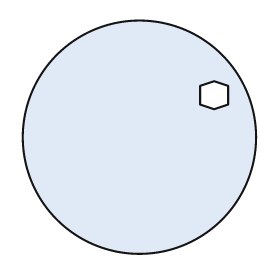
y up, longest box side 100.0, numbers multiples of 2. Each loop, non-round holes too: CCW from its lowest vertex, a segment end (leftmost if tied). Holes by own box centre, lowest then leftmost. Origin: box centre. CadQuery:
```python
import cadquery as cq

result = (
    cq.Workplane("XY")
    .moveTo(0.0, 0.0)
    .circle(50.0)
    .moveTo(32.0, 12.0)
    .lineTo(38.0, 14.0)
    .lineTo(38.0, 22.0)
    .lineTo(32.0, 24.0)
    .lineTo(26.0, 22.0)
    .lineTo(26.0, 14.0)
    .close()
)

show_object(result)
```